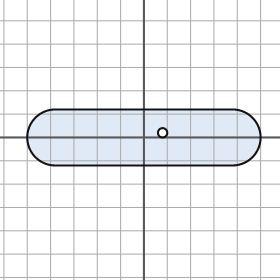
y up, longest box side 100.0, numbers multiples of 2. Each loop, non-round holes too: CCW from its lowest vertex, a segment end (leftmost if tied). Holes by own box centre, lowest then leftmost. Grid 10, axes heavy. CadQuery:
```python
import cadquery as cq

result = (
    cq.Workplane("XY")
    .moveTo(-38.0, -12.0)
    .lineTo(38.0, -12.0)
    .threePointArc((50.0, 0.0), (38.0, 12.0))
    .lineTo(-38.0, 12.0)
    .threePointArc((-50.0, 0.0), (-38.0, -12.0))
    .close()
    .moveTo(8.0, 2.0)
    .circle(2.0)
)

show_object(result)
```